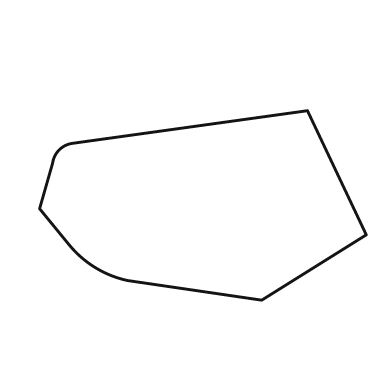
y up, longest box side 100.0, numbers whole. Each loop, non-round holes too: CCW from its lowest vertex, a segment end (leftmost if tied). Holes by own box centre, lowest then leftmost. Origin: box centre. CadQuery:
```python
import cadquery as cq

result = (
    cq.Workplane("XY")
    .moveTo(18.0, -29.0)
    .lineTo(50.0, -9.0)
    .lineTo(32.0, 29.0)
    .lineTo(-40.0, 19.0)
    .threePointArc((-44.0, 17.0), (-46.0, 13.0))
    .lineTo(-50.0, -1.0)
    .lineTo(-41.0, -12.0)
    .threePointArc((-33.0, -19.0), (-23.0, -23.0))
    .close()
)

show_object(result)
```